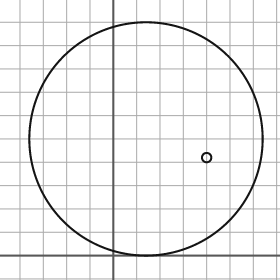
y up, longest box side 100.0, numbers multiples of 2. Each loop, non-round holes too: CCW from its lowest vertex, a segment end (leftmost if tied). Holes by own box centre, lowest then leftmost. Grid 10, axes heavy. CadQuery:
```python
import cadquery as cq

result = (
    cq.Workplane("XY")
    .moveTo(14.0, 50.0)
    .circle(50.0)
    .moveTo(40.0, 42.0)
    .circle(2.0)
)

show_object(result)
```